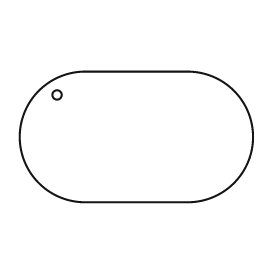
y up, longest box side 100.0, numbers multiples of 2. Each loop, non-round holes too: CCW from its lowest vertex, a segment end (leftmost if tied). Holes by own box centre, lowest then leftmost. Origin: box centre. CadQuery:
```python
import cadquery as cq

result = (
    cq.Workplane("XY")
    .moveTo(-22.0, -28.0)
    .lineTo(22.0, -28.0)
    .threePointArc((50.0, 0.0), (22.0, 28.0))
    .lineTo(-22.0, 28.0)
    .threePointArc((-50.0, 0.0), (-22.0, -28.0))
    .close()
    .moveTo(-34.0, 18.0)
    .circle(2.0)
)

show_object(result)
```